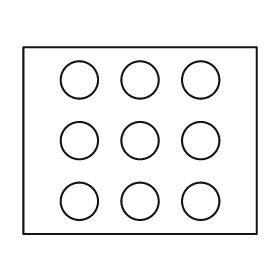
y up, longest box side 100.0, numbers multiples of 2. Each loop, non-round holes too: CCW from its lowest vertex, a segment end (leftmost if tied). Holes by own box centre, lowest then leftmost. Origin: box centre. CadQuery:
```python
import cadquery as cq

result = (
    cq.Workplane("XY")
    .moveTo(-50.0, -40.0)
    .lineTo(50.0, -40.0)
    .lineTo(50.0, 40.0)
    .lineTo(-50.0, 40.0)
    .close()
    .moveTo(-26.0, -26.0)
    .circle(8.0)
    .moveTo(0.0, -26.0)
    .circle(8.0)
    .moveTo(26.0, -26.0)
    .circle(8.0)
    .moveTo(-26.0, 0.0)
    .circle(8.0)
    .moveTo(0.0, 0.0)
    .circle(8.0)
    .moveTo(26.0, 0.0)
    .circle(8.0)
    .moveTo(-26.0, 26.0)
    .circle(8.0)
    .moveTo(0.0, 26.0)
    .circle(8.0)
    .moveTo(26.0, 26.0)
    .circle(8.0)
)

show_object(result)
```